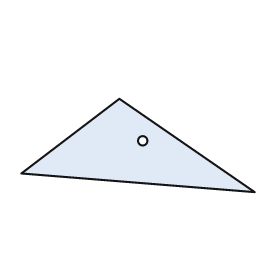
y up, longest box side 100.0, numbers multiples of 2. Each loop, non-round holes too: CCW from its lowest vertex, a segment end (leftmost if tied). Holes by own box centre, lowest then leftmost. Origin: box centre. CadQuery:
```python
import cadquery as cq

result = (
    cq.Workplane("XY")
    .moveTo(50.0, -20.0)
    .lineTo(-8.0, 20.0)
    .lineTo(-50.0, -12.0)
    .close()
    .moveTo(2.0, 2.0)
    .circle(2.0)
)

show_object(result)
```